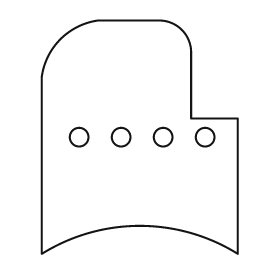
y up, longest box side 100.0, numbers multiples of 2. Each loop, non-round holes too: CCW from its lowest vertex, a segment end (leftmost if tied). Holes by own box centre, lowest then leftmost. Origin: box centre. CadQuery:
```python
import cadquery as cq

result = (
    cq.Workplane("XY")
    .moveTo(-42.0, -50.0)
    .threePointArc((0.0, -38.0), (42.0, -50.0))
    .lineTo(42.0, 8.0)
    .lineTo(22.0, 8.0)
    .lineTo(22.0, 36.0)
    .threePointArc((18.0, 46.0), (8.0, 50.0))
    .lineTo(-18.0, 50.0)
    .threePointArc((-34.0, 42.0), (-42.0, 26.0))
    .close()
    .moveTo(-26.0, 0.0)
    .circle(4.0)
    .moveTo(-8.0, 0.0)
    .circle(4.0)
    .moveTo(10.0, 0.0)
    .circle(4.0)
    .moveTo(28.0, 0.0)
    .circle(4.0)
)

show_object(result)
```